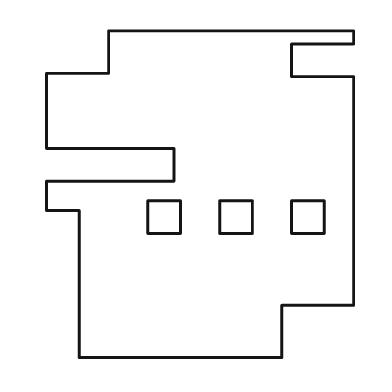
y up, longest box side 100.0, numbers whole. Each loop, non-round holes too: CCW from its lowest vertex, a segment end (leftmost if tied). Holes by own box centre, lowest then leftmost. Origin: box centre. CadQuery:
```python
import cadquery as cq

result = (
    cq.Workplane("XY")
    .moveTo(-37.0, -50.0)
    .lineTo(25.0, -50.0)
    .lineTo(25.0, -34.0)
    .lineTo(47.0, -34.0)
    .lineTo(47.0, 36.0)
    .lineTo(28.0, 36.0)
    .lineTo(28.0, 46.0)
    .lineTo(47.0, 46.0)
    .lineTo(47.0, 50.0)
    .lineTo(-28.0, 50.0)
    .lineTo(-28.0, 37.0)
    .lineTo(-47.0, 37.0)
    .lineTo(-47.0, 14.0)
    .lineTo(-8.0, 14.0)
    .lineTo(-8.0, 4.0)
    .lineTo(-47.0, 4.0)
    .lineTo(-47.0, -5.0)
    .lineTo(-37.0, -5.0)
    .close()
    .moveTo(-16.0, -12.0)
    .lineTo(-6.0, -12.0)
    .lineTo(-6.0, -2.0)
    .lineTo(-16.0, -2.0)
    .close()
    .moveTo(6.0, -12.0)
    .lineTo(16.0, -12.0)
    .lineTo(16.0, -2.0)
    .lineTo(6.0, -2.0)
    .close()
    .moveTo(28.0, -12.0)
    .lineTo(38.0, -12.0)
    .lineTo(38.0, -2.0)
    .lineTo(28.0, -2.0)
    .close()
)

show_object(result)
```